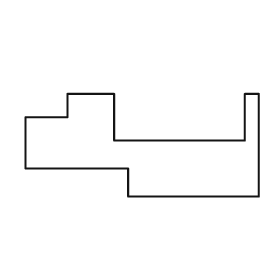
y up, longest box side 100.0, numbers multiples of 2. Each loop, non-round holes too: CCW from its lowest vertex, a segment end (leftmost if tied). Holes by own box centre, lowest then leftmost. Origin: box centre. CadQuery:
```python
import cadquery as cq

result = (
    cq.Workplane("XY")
    .moveTo(-6.0, -22.0)
    .lineTo(50.0, -22.0)
    .lineTo(50.0, 22.0)
    .lineTo(44.0, 22.0)
    .lineTo(44.0, 2.0)
    .lineTo(-12.0, 2.0)
    .lineTo(-12.0, 22.0)
    .lineTo(-32.0, 22.0)
    .lineTo(-32.0, 12.0)
    .lineTo(-50.0, 12.0)
    .lineTo(-50.0, -10.0)
    .lineTo(-6.0, -10.0)
    .close()
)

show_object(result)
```